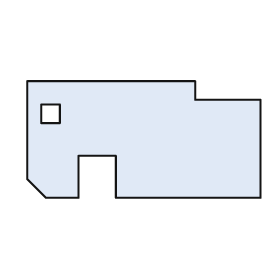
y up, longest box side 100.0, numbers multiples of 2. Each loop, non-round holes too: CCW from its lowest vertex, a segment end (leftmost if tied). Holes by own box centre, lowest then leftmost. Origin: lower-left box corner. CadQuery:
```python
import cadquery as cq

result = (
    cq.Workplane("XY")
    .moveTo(8.0, 0.0)
    .lineTo(22.0, 0.0)
    .lineTo(22.0, 18.0)
    .lineTo(38.0, 18.0)
    .lineTo(38.0, 0.0)
    .lineTo(100.0, 0.0)
    .lineTo(100.0, 42.0)
    .lineTo(72.0, 42.0)
    .lineTo(72.0, 50.0)
    .lineTo(0.0, 50.0)
    .lineTo(0.0, 8.0)
    .close()
    .moveTo(6.0, 32.0)
    .lineTo(14.0, 32.0)
    .lineTo(14.0, 40.0)
    .lineTo(6.0, 40.0)
    .close()
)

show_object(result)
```